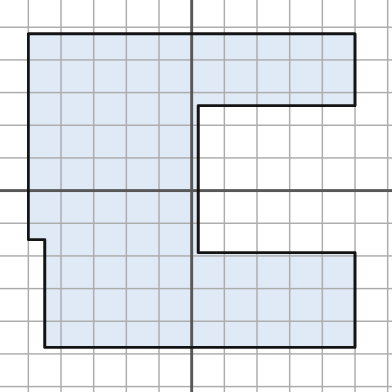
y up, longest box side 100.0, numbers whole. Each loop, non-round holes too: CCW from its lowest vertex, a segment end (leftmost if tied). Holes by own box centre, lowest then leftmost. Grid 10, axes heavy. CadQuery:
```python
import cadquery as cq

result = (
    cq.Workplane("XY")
    .moveTo(-45.0, -48.0)
    .lineTo(50.0, -48.0)
    .lineTo(50.0, -19.0)
    .lineTo(2.0, -19.0)
    .lineTo(2.0, 26.0)
    .lineTo(50.0, 26.0)
    .lineTo(50.0, 48.0)
    .lineTo(-50.0, 48.0)
    .lineTo(-50.0, -15.0)
    .lineTo(-45.0, -15.0)
    .close()
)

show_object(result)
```